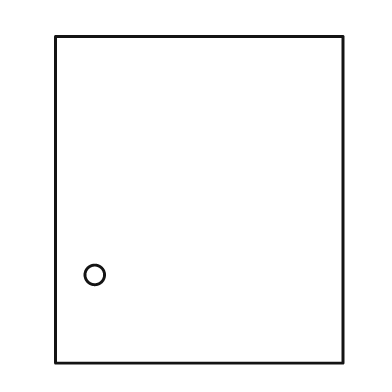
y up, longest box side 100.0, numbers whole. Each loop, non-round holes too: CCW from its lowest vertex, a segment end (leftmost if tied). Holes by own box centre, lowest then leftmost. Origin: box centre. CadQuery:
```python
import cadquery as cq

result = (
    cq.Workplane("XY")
    .moveTo(-44.0, -50.0)
    .lineTo(44.0, -50.0)
    .lineTo(44.0, 50.0)
    .lineTo(-44.0, 50.0)
    .close()
    .moveTo(-32.0, -23.0)
    .circle(3.0)
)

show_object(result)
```